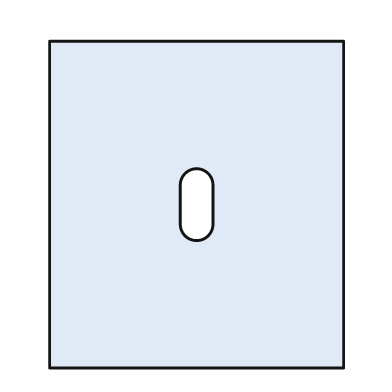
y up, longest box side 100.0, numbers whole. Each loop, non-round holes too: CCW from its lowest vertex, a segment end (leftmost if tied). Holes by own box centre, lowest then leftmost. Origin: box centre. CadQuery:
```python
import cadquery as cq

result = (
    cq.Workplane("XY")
    .moveTo(-45.0, -50.0)
    .lineTo(45.0, -50.0)
    .lineTo(45.0, 50.0)
    .lineTo(-45.0, 50.0)
    .close()
    .moveTo(-5.0, -6.0)
    .threePointArc((0.0, -11.0), (5.0, -6.0))
    .lineTo(5.0, 6.0)
    .threePointArc((0.0, 11.0), (-5.0, 6.0))
    .close()
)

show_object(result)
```